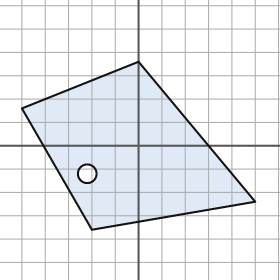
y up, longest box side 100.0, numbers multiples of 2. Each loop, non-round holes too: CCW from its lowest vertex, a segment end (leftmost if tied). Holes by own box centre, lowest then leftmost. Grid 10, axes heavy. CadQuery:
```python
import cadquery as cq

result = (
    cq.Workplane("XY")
    .moveTo(-20.0, -36.0)
    .lineTo(50.0, -24.0)
    .lineTo(0.0, 36.0)
    .lineTo(-50.0, 16.0)
    .close()
    .moveTo(-22.0, -12.0)
    .circle(4.0)
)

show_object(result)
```